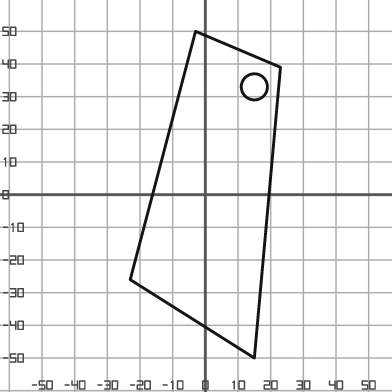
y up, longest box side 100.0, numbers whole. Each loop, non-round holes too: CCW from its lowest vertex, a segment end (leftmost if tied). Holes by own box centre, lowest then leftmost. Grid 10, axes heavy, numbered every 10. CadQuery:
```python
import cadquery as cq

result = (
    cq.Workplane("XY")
    .moveTo(15.0, -50.0)
    .lineTo(23.0, 39.0)
    .lineTo(-3.0, 50.0)
    .lineTo(-23.0, -26.0)
    .close()
    .moveTo(15.0, 33.0)
    .circle(4.0)
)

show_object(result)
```